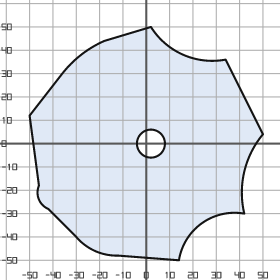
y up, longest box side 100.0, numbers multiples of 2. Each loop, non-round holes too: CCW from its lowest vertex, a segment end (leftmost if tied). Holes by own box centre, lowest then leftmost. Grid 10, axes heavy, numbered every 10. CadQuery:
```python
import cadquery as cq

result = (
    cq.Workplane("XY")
    .moveTo(14.0, -50.0)
    .threePointArc((24.0, -34.0), (42.0, -30.0))
    .threePointArc((42.0, -12.0), (50.0, 4.0))
    .lineTo(34.0, 36.0)
    .threePointArc((16.0, 38.0), (2.0, 50.0))
    .lineTo(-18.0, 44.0)
    .threePointArc((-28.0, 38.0), (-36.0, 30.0))
    .lineTo(-50.0, 12.0)
    .lineTo(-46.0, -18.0)
    .threePointArc((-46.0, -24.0), (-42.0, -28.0))
    .lineTo(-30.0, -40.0)
    .threePointArc((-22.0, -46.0), (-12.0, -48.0))
    .close()
    .moveTo(2.0, 0.0)
    .circle(6.0)
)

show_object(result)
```